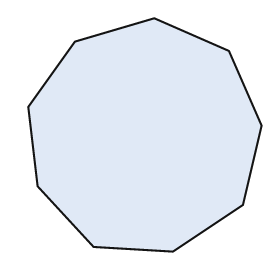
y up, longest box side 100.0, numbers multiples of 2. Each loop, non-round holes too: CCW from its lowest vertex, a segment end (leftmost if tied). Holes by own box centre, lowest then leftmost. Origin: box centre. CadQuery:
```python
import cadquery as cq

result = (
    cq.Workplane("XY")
    .moveTo(12.0, -50.0)
    .lineTo(42.0, -30.0)
    .lineTo(50.0, 4.0)
    .lineTo(36.0, 36.0)
    .lineTo(4.0, 50.0)
    .lineTo(-30.0, 40.0)
    .lineTo(-50.0, 12.0)
    .lineTo(-46.0, -22.0)
    .lineTo(-22.0, -48.0)
    .close()
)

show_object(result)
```